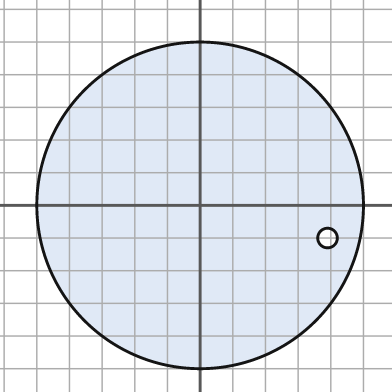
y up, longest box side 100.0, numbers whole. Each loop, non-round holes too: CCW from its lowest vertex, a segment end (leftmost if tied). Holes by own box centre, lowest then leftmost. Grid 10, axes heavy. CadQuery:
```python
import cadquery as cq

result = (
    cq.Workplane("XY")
    .moveTo(0.0, 0.0)
    .circle(50.0)
    .moveTo(39.0, -10.0)
    .circle(3.0)
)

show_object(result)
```